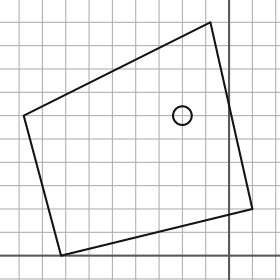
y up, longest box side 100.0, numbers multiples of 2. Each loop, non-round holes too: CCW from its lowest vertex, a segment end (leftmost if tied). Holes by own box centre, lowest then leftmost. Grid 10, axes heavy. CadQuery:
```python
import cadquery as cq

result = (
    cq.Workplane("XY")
    .moveTo(-72.0, 0.0)
    .lineTo(10.0, 20.0)
    .lineTo(-8.0, 100.0)
    .lineTo(-88.0, 60.0)
    .close()
    .moveTo(-20.0, 60.0)
    .circle(4.0)
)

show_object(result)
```